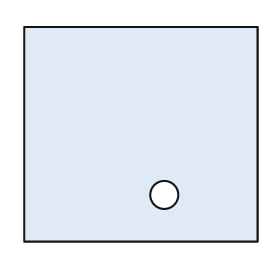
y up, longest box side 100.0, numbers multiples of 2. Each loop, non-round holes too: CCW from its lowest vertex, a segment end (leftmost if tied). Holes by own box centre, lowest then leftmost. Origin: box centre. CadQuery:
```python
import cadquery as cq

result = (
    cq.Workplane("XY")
    .moveTo(-50.0, -46.0)
    .lineTo(50.0, -46.0)
    .lineTo(50.0, 46.0)
    .lineTo(-50.0, 46.0)
    .close()
    .moveTo(10.0, -26.0)
    .circle(6.0)
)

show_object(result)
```